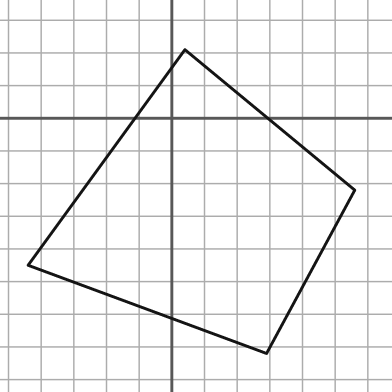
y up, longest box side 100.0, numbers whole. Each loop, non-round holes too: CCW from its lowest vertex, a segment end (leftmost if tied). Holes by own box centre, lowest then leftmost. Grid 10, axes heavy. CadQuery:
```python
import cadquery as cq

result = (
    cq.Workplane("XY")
    .moveTo(29.0, -72.0)
    .lineTo(56.0, -22.0)
    .lineTo(4.0, 21.0)
    .lineTo(-44.0, -45.0)
    .close()
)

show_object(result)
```